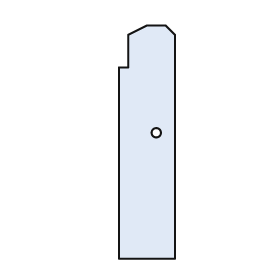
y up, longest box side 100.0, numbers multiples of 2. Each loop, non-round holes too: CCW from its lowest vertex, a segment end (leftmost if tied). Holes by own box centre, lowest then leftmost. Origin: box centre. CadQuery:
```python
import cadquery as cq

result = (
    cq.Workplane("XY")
    .moveTo(-12.0, -50.0)
    .lineTo(12.0, -50.0)
    .lineTo(12.0, 46.0)
    .lineTo(8.0, 50.0)
    .lineTo(0.0, 50.0)
    .lineTo(-8.0, 46.0)
    .lineTo(-8.0, 32.0)
    .lineTo(-12.0, 32.0)
    .close()
    .moveTo(4.0, 4.0)
    .circle(2.0)
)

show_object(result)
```